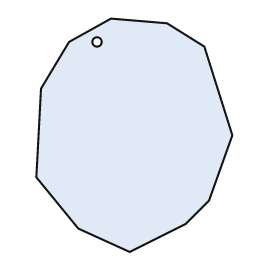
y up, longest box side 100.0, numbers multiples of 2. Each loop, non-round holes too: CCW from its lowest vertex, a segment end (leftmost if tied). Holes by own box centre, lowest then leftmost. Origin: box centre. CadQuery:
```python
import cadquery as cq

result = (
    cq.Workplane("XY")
    .moveTo(-2.0, -50.0)
    .lineTo(22.0, -38.0)
    .lineTo(32.0, -28.0)
    .lineTo(42.0, 0.0)
    .lineTo(30.0, 38.0)
    .lineTo(14.0, 48.0)
    .lineTo(-10.0, 50.0)
    .lineTo(-28.0, 40.0)
    .lineTo(-40.0, 20.0)
    .lineTo(-42.0, -18.0)
    .lineTo(-24.0, -40.0)
    .close()
    .moveTo(-16.0, 40.0)
    .circle(2.0)
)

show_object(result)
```